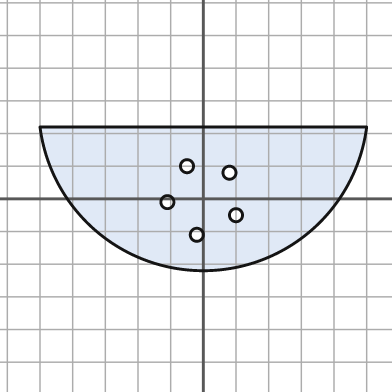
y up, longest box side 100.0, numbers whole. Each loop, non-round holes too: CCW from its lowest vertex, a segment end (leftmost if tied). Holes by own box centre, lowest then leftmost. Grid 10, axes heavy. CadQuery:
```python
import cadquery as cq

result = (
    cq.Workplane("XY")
    .moveTo(-50.0, 22.0)
    .threePointArc((0.0, -22.0), (50.0, 22.0))
    .close()
    .moveTo(-2.0, -11.0)
    .circle(2.0)
    .moveTo(10.0, -5.0)
    .circle(2.0)
    .moveTo(-11.0, -1.0)
    .circle(2.0)
    .moveTo(8.0, 8.0)
    .circle(2.0)
    .moveTo(-5.0, 10.0)
    .circle(2.0)
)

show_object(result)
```